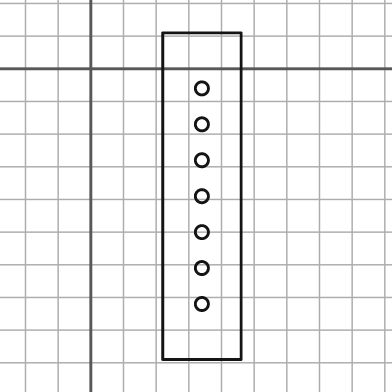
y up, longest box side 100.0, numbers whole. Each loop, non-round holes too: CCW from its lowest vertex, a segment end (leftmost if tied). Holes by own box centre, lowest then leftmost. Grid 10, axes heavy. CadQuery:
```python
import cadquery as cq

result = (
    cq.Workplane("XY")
    .moveTo(22.0, -89.0)
    .lineTo(46.0, -89.0)
    .lineTo(46.0, 11.0)
    .lineTo(22.0, 11.0)
    .close()
    .moveTo(34.0, -72.0)
    .circle(2.0)
    .moveTo(34.0, -61.0)
    .circle(2.0)
    .moveTo(34.0, -50.0)
    .circle(2.0)
    .moveTo(34.0, -39.0)
    .circle(2.0)
    .moveTo(34.0, -28.0)
    .circle(2.0)
    .moveTo(34.0, -17.0)
    .circle(2.0)
    .moveTo(34.0, -6.0)
    .circle(2.0)
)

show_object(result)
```